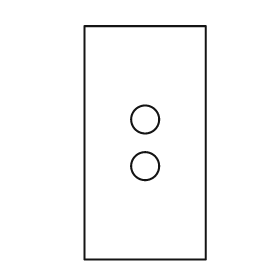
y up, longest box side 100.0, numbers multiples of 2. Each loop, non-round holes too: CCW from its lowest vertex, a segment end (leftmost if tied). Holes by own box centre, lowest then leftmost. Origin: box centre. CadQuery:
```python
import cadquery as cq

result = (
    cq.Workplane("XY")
    .moveTo(-26.0, -50.0)
    .lineTo(26.0, -50.0)
    .lineTo(26.0, 50.0)
    .lineTo(-26.0, 50.0)
    .close()
    .moveTo(0.0, -10.0)
    .circle(6.0)
    .moveTo(0.0, 10.0)
    .circle(6.0)
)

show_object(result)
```